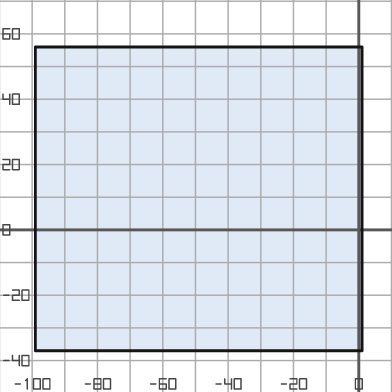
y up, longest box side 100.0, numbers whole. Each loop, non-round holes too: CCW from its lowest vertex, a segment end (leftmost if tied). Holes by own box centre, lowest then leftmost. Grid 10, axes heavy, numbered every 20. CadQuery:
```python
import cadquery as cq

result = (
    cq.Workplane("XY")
    .moveTo(-99.0, -37.0)
    .lineTo(1.0, -37.0)
    .lineTo(1.0, 56.0)
    .lineTo(-99.0, 56.0)
    .close()
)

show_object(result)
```